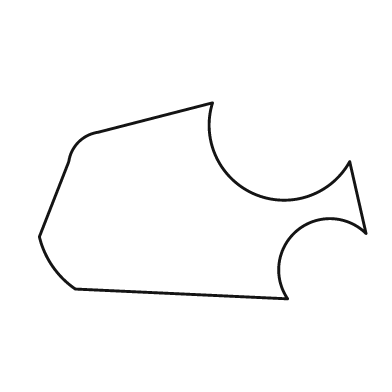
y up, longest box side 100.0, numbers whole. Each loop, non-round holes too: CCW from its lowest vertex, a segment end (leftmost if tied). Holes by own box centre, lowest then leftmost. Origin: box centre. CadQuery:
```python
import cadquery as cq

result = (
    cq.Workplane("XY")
    .moveTo(26.0, -30.0)
    .threePointArc((29.0, -9.0), (50.0, -10.0))
    .lineTo(45.0, 12.0)
    .threePointArc((16.0, 2.0), (3.0, 30.0))
    .lineTo(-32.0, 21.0)
    .threePointArc((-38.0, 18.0), (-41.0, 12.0))
    .lineTo(-50.0, -11.0)
    .threePointArc((-46.0, -20.0), (-39.0, -27.0))
    .close()
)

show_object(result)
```